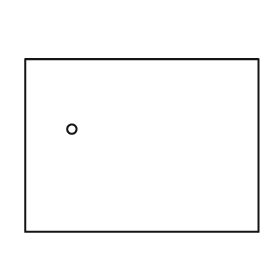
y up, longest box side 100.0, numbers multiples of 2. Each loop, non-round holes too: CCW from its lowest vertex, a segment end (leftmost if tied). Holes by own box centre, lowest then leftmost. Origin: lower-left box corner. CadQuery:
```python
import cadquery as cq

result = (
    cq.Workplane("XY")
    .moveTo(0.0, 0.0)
    .lineTo(100.0, 0.0)
    .lineTo(100.0, 74.0)
    .lineTo(0.0, 74.0)
    .close()
    .moveTo(20.0, 44.0)
    .circle(2.0)
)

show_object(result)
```